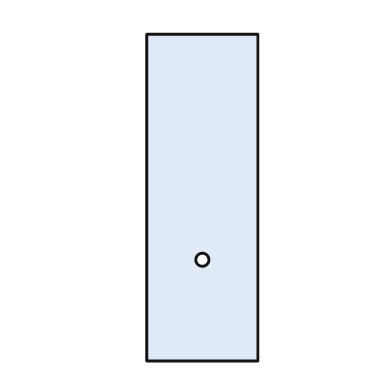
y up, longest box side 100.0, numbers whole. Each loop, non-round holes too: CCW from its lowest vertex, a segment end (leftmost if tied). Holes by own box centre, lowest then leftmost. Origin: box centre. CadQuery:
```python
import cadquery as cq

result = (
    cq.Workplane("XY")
    .moveTo(-17.0, -50.0)
    .lineTo(17.0, -50.0)
    .lineTo(17.0, 50.0)
    .lineTo(-17.0, 50.0)
    .close()
    .moveTo(0.0, -19.0)
    .circle(2.0)
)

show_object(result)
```